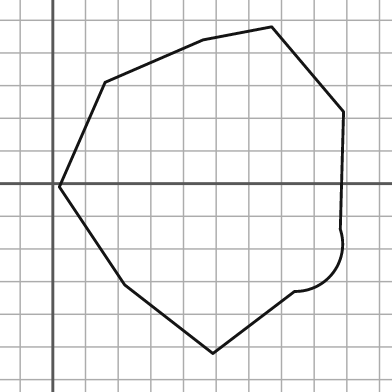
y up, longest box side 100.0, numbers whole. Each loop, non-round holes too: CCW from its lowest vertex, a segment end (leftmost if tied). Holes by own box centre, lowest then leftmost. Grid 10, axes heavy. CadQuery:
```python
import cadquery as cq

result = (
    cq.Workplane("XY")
    .moveTo(49.0, -52.0)
    .lineTo(74.0, -33.0)
    .threePointArc((86.0, -27.0), (88.0, -14.0))
    .lineTo(89.0, 22.0)
    .lineTo(67.0, 48.0)
    .lineTo(46.0, 44.0)
    .lineTo(16.0, 31.0)
    .lineTo(2.0, -1.0)
    .lineTo(22.0, -31.0)
    .close()
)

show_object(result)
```